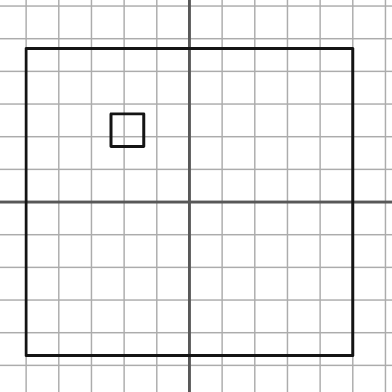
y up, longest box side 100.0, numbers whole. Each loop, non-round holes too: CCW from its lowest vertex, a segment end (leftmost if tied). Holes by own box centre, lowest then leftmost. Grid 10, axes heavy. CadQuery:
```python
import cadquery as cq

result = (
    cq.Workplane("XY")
    .moveTo(-50.0, -47.0)
    .lineTo(50.0, -47.0)
    .lineTo(50.0, 47.0)
    .lineTo(-50.0, 47.0)
    .close()
    .moveTo(-24.0, 17.0)
    .lineTo(-14.0, 17.0)
    .lineTo(-14.0, 27.0)
    .lineTo(-24.0, 27.0)
    .close()
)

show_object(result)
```